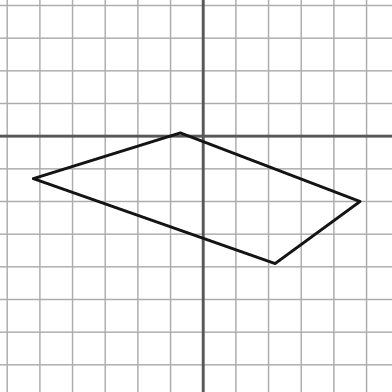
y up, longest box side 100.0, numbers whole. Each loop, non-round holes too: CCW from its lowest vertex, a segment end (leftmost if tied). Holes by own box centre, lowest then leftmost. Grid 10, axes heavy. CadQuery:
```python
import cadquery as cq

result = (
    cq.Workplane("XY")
    .moveTo(22.0, -39.0)
    .lineTo(48.0, -20.0)
    .lineTo(-7.0, 1.0)
    .lineTo(-52.0, -13.0)
    .close()
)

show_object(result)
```